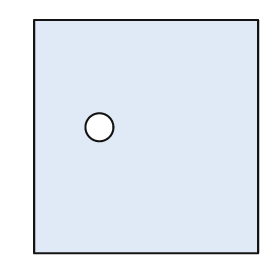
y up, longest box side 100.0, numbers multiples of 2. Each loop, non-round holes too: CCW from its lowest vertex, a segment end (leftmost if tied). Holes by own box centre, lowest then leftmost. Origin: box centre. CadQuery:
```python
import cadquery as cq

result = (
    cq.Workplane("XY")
    .moveTo(-48.0, -50.0)
    .lineTo(48.0, -50.0)
    .lineTo(48.0, 50.0)
    .lineTo(-48.0, 50.0)
    .close()
    .moveTo(-20.0, 4.0)
    .circle(6.0)
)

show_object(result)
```